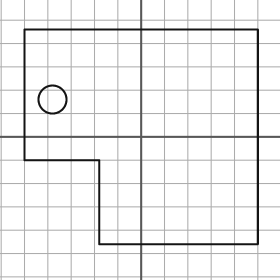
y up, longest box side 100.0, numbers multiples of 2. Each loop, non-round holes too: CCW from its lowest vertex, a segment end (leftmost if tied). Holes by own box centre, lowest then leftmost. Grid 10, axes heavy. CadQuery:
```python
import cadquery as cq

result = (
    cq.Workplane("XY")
    .moveTo(-18.0, -46.0)
    .lineTo(50.0, -46.0)
    .lineTo(50.0, 46.0)
    .lineTo(-50.0, 46.0)
    .lineTo(-50.0, -10.0)
    .lineTo(-18.0, -10.0)
    .close()
    .moveTo(-38.0, 16.0)
    .circle(6.0)
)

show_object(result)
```